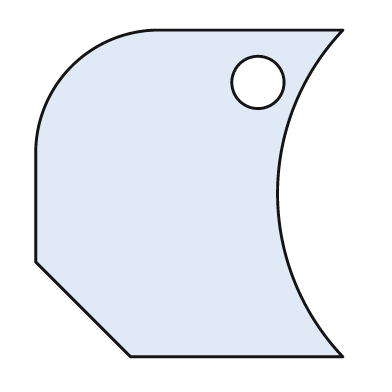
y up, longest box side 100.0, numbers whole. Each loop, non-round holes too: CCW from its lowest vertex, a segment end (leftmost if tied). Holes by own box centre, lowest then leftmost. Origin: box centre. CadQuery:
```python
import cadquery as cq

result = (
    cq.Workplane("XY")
    .moveTo(-18.0, -50.0)
    .lineTo(47.0, -50.0)
    .threePointArc((27.0, 0.0), (47.0, 50.0))
    .lineTo(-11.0, 50.0)
    .threePointArc((-36.0, 39.0), (-47.0, 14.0))
    .lineTo(-47.0, -21.0)
    .close()
    .moveTo(21.0, 34.0)
    .circle(8.0)
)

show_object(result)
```